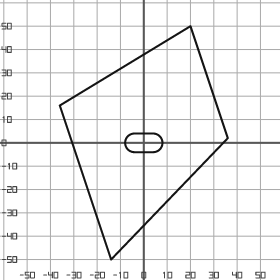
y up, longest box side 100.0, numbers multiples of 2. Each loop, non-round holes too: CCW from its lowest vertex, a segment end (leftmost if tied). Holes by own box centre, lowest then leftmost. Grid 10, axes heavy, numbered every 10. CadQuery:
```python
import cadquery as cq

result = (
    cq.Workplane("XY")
    .moveTo(-14.0, -50.0)
    .lineTo(36.0, 2.0)
    .lineTo(20.0, 50.0)
    .lineTo(-36.0, 16.0)
    .close()
    .moveTo(-4.0, -4.0)
    .lineTo(4.0, -4.0)
    .threePointArc((8.0, 0.0), (4.0, 4.0))
    .lineTo(-4.0, 4.0)
    .threePointArc((-8.0, 0.0), (-4.0, -4.0))
    .close()
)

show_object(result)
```